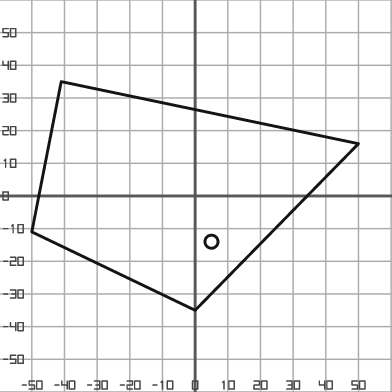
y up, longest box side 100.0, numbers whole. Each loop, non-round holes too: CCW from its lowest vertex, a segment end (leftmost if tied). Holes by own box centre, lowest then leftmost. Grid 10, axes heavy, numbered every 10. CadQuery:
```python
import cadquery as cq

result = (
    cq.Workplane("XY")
    .moveTo(0.0, -35.0)
    .lineTo(50.0, 16.0)
    .lineTo(-41.0, 35.0)
    .lineTo(-50.0, -11.0)
    .close()
    .moveTo(5.0, -14.0)
    .circle(2.0)
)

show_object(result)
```